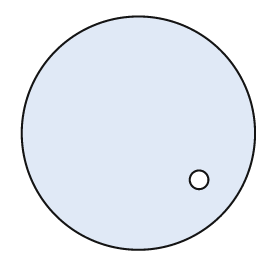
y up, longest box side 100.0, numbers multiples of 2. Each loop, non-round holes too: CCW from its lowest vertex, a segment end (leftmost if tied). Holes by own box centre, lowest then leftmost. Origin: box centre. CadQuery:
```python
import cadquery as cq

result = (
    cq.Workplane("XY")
    .moveTo(0.0, 0.0)
    .circle(50.0)
    .moveTo(26.0, -20.0)
    .circle(4.0)
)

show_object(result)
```